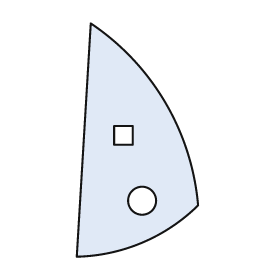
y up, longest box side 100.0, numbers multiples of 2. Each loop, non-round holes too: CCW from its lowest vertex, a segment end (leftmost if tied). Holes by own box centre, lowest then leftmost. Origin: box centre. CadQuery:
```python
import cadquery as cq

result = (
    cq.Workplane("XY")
    .moveTo(-26.0, -50.0)
    .threePointArc((2.0, -44.0), (26.0, -28.0))
    .threePointArc((12.0, 16.0), (-20.0, 50.0))
    .close()
    .moveTo(2.0, -26.0)
    .circle(6.0)
    .moveTo(-10.0, -2.0)
    .lineTo(-2.0, -2.0)
    .lineTo(-2.0, 6.0)
    .lineTo(-10.0, 6.0)
    .close()
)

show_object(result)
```